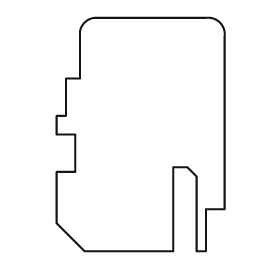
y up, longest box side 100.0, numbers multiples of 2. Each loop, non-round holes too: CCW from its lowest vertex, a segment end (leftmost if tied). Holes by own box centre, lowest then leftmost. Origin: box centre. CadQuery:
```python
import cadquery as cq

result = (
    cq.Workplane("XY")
    .moveTo(-24.0, -50.0)
    .lineTo(14.0, -50.0)
    .lineTo(14.0, -14.0)
    .lineTo(20.0, -14.0)
    .lineTo(24.0, -18.0)
    .lineTo(24.0, -50.0)
    .lineTo(28.0, -50.0)
    .lineTo(28.0, -32.0)
    .lineTo(36.0, -32.0)
    .lineTo(36.0, 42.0)
    .threePointArc((34.0, 48.0), (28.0, 50.0))
    .lineTo(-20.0, 50.0)
    .threePointArc((-24.0, 48.0), (-26.0, 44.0))
    .lineTo(-26.0, 24.0)
    .lineTo(-32.0, 24.0)
    .lineTo(-32.0, 8.0)
    .lineTo(-36.0, 8.0)
    .lineTo(-36.0, 0.0)
    .lineTo(-28.0, 0.0)
    .lineTo(-28.0, -16.0)
    .lineTo(-36.0, -16.0)
    .lineTo(-36.0, -38.0)
    .close()
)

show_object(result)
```